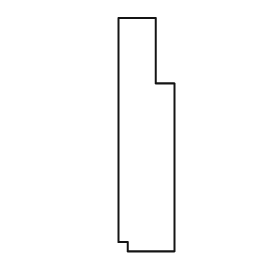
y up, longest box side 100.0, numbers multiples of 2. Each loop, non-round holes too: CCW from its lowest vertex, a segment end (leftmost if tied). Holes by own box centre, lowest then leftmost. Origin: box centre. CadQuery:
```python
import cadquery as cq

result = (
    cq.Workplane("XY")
    .moveTo(-8.0, -50.0)
    .lineTo(12.0, -50.0)
    .lineTo(12.0, 22.0)
    .lineTo(4.0, 22.0)
    .lineTo(4.0, 50.0)
    .lineTo(-12.0, 50.0)
    .lineTo(-12.0, -46.0)
    .lineTo(-8.0, -46.0)
    .close()
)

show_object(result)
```